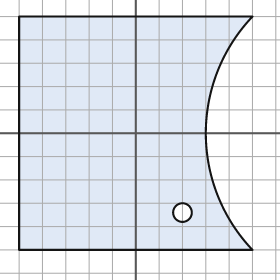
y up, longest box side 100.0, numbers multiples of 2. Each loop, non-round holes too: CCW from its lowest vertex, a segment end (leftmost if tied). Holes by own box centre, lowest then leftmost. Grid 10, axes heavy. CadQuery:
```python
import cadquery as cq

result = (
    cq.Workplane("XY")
    .moveTo(-50.0, -50.0)
    .lineTo(50.0, -50.0)
    .threePointArc((30.0, 0.0), (50.0, 50.0))
    .lineTo(-50.0, 50.0)
    .close()
    .moveTo(20.0, -34.0)
    .circle(4.0)
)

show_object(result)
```